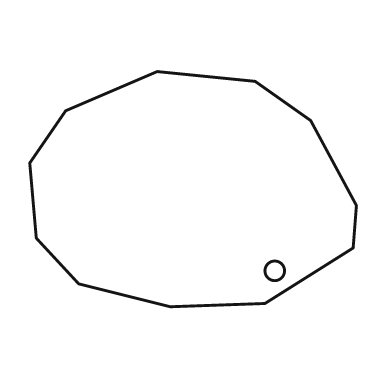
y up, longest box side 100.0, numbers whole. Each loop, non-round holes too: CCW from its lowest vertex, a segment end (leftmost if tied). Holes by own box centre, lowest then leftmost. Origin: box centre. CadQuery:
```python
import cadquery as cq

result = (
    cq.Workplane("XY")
    .moveTo(-7.0, -36.0)
    .lineTo(22.0, -35.0)
    .lineTo(49.0, -18.0)
    .lineTo(50.0, -5.0)
    .lineTo(36.0, 21.0)
    .lineTo(19.0, 33.0)
    .lineTo(-11.0, 36.0)
    .lineTo(-39.0, 24.0)
    .lineTo(-50.0, 8.0)
    .lineTo(-48.0, -15.0)
    .lineTo(-35.0, -29.0)
    .close()
    .moveTo(25.0, -25.0)
    .circle(3.0)
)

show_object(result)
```